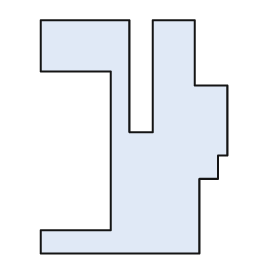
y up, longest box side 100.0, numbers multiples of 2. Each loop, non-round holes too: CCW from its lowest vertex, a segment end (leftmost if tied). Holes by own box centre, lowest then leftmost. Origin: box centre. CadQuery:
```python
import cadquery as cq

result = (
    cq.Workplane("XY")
    .moveTo(-40.0, -50.0)
    .lineTo(28.0, -50.0)
    .lineTo(28.0, -18.0)
    .lineTo(36.0, -18.0)
    .lineTo(36.0, -8.0)
    .lineTo(40.0, -8.0)
    .lineTo(40.0, 22.0)
    .lineTo(26.0, 22.0)
    .lineTo(26.0, 50.0)
    .lineTo(8.0, 50.0)
    .lineTo(8.0, 2.0)
    .lineTo(-2.0, 2.0)
    .lineTo(-2.0, 50.0)
    .lineTo(-40.0, 50.0)
    .lineTo(-40.0, 28.0)
    .lineTo(-10.0, 28.0)
    .lineTo(-10.0, -40.0)
    .lineTo(-40.0, -40.0)
    .close()
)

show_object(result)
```